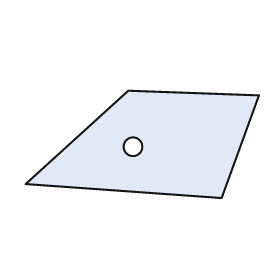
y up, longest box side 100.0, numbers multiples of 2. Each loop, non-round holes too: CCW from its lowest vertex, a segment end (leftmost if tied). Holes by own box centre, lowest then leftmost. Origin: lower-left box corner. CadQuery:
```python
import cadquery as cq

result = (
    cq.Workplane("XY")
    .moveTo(84.0, 0.0)
    .lineTo(100.0, 44.0)
    .lineTo(44.0, 46.0)
    .lineTo(0.0, 6.0)
    .close()
    .moveTo(46.0, 22.0)
    .circle(4.0)
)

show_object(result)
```